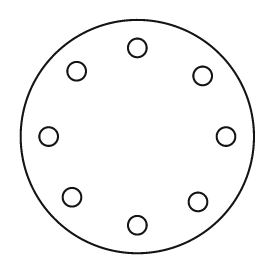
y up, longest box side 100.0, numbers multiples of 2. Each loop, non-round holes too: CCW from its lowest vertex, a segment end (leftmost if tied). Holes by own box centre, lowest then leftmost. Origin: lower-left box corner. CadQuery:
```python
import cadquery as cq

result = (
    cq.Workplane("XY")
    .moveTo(50.0, 50.0)
    .circle(50.0)
    .moveTo(50.0, 12.0)
    .circle(4.0)
    .moveTo(76.0, 22.0)
    .circle(4.0)
    .moveTo(22.0, 24.0)
    .circle(4.0)
    .moveTo(12.0, 50.0)
    .circle(4.0)
    .moveTo(88.0, 50.0)
    .circle(4.0)
    .moveTo(78.0, 76.0)
    .circle(4.0)
    .moveTo(24.0, 78.0)
    .circle(4.0)
    .moveTo(50.0, 88.0)
    .circle(4.0)
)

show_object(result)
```